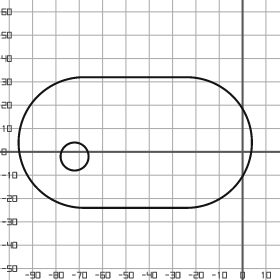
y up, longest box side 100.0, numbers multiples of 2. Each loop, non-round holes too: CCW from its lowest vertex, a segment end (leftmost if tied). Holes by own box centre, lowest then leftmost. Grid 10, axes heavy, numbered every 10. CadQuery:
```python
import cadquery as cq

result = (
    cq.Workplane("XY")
    .moveTo(-68.0, -24.0)
    .lineTo(-24.0, -24.0)
    .threePointArc((4.0, 4.0), (-24.0, 32.0))
    .lineTo(-68.0, 32.0)
    .threePointArc((-96.0, 4.0), (-68.0, -24.0))
    .close()
    .moveTo(-72.0, -2.0)
    .circle(6.0)
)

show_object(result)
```